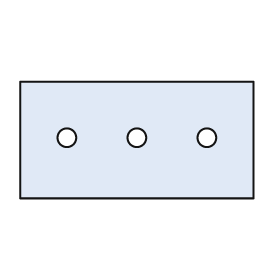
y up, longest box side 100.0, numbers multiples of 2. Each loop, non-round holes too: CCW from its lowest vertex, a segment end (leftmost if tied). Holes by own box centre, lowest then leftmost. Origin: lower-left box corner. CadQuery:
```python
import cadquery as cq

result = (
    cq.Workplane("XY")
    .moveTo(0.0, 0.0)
    .lineTo(100.0, 0.0)
    .lineTo(100.0, 50.0)
    .lineTo(0.0, 50.0)
    .close()
    .moveTo(20.0, 26.0)
    .circle(4.0)
    .moveTo(50.0, 26.0)
    .circle(4.0)
    .moveTo(80.0, 26.0)
    .circle(4.0)
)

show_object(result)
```